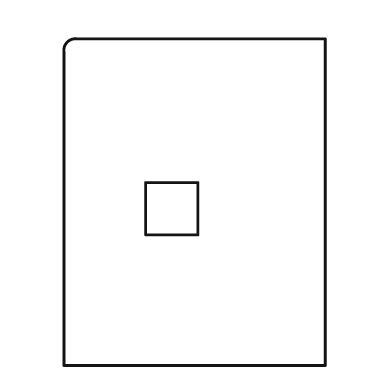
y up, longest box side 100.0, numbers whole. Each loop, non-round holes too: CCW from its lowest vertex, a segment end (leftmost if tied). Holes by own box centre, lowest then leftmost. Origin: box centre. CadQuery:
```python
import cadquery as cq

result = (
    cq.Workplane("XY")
    .moveTo(-40.0, -50.0)
    .lineTo(40.0, -50.0)
    .lineTo(40.0, 50.0)
    .lineTo(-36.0, 50.0)
    .threePointArc((-39.0, 49.0), (-40.0, 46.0))
    .close()
    .moveTo(-15.0, -10.0)
    .lineTo(1.0, -10.0)
    .lineTo(1.0, 6.0)
    .lineTo(-15.0, 6.0)
    .close()
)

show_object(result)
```